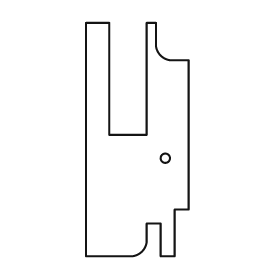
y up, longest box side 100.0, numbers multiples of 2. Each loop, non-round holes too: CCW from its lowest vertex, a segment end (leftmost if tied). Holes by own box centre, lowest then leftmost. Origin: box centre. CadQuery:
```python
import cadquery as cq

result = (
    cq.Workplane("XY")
    .moveTo(-22.0, -50.0)
    .lineTo(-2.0, -50.0)
    .threePointArc((2.0, -48.0), (4.0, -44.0))
    .lineTo(4.0, -36.0)
    .lineTo(10.0, -36.0)
    .lineTo(10.0, -50.0)
    .lineTo(16.0, -50.0)
    .lineTo(16.0, -30.0)
    .lineTo(22.0, -30.0)
    .lineTo(22.0, 34.0)
    .lineTo(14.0, 34.0)
    .threePointArc((10.0, 36.0), (8.0, 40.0))
    .lineTo(8.0, 50.0)
    .lineTo(4.0, 50.0)
    .lineTo(4.0, 2.0)
    .lineTo(-12.0, 2.0)
    .lineTo(-12.0, 50.0)
    .lineTo(-22.0, 50.0)
    .close()
    .moveTo(12.0, -8.0)
    .circle(2.0)
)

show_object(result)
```